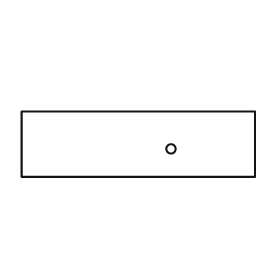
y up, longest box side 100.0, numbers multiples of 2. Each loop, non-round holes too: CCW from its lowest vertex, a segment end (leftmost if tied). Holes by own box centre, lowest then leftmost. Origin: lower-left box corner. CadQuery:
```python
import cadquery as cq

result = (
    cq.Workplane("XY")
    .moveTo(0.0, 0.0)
    .lineTo(100.0, 0.0)
    .lineTo(100.0, 28.0)
    .lineTo(0.0, 28.0)
    .close()
    .moveTo(64.0, 12.0)
    .circle(2.0)
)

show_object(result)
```